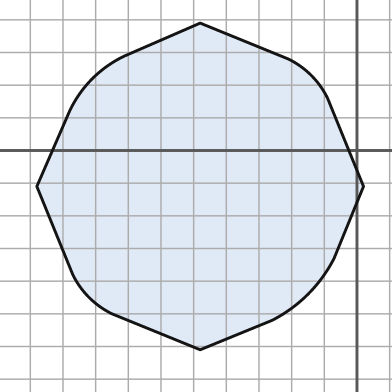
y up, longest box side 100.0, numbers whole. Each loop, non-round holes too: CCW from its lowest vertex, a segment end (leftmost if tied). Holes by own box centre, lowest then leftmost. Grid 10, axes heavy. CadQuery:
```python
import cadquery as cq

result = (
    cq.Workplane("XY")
    .moveTo(-48.0, -61.0)
    .lineTo(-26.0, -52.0)
    .threePointArc((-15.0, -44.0), (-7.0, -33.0))
    .lineTo(2.0, -11.0)
    .lineTo(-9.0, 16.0)
    .threePointArc((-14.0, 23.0), (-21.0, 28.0))
    .lineTo(-48.0, 39.0)
    .lineTo(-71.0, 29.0)
    .threePointArc((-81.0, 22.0), (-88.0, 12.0))
    .lineTo(-98.0, -11.0)
    .lineTo(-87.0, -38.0)
    .threePointArc((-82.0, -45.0), (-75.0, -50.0))
    .close()
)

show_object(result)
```